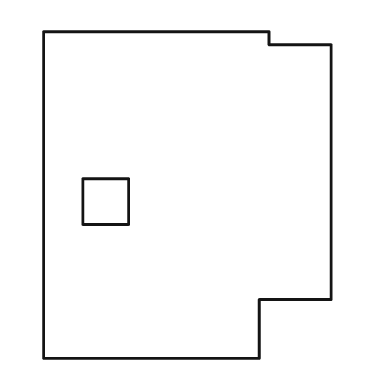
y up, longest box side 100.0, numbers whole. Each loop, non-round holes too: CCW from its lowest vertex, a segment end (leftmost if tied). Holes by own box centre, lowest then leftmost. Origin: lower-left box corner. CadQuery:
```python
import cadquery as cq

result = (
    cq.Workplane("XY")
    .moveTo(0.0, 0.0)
    .lineTo(66.0, 0.0)
    .lineTo(66.0, 18.0)
    .lineTo(88.0, 18.0)
    .lineTo(88.0, 96.0)
    .lineTo(69.0, 96.0)
    .lineTo(69.0, 100.0)
    .lineTo(0.0, 100.0)
    .close()
    .moveTo(12.0, 41.0)
    .lineTo(26.0, 41.0)
    .lineTo(26.0, 55.0)
    .lineTo(12.0, 55.0)
    .close()
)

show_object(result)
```